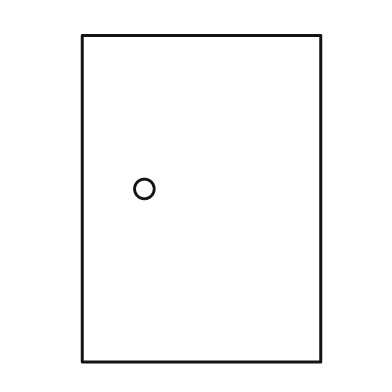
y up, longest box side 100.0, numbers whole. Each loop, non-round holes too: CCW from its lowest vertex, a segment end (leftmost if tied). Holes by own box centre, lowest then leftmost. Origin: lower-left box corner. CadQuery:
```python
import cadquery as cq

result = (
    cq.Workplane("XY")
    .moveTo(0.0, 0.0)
    .lineTo(73.0, 0.0)
    .lineTo(73.0, 100.0)
    .lineTo(0.0, 100.0)
    .close()
    .moveTo(19.0, 53.0)
    .circle(3.0)
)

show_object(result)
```